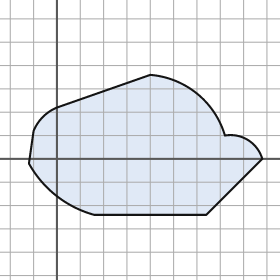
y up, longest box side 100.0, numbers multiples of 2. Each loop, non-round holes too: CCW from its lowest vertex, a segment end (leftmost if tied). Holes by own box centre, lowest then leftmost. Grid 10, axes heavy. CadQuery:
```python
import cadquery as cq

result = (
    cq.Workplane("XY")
    .moveTo(16.0, -24.0)
    .lineTo(64.0, -24.0)
    .lineTo(88.0, 0.0)
    .threePointArc((82.0, 8.0), (72.0, 10.0))
    .threePointArc((60.0, 28.0), (40.0, 36.0))
    .lineTo(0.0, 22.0)
    .threePointArc((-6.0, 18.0), (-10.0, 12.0))
    .lineTo(-12.0, -2.0)
    .threePointArc((0.0, -16.0), (16.0, -24.0))
    .close()
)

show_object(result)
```